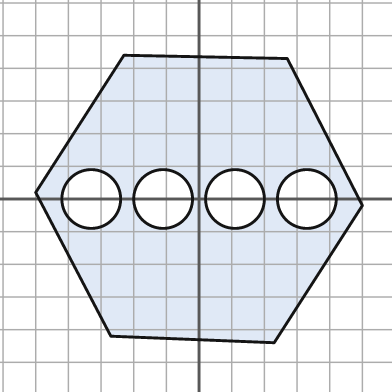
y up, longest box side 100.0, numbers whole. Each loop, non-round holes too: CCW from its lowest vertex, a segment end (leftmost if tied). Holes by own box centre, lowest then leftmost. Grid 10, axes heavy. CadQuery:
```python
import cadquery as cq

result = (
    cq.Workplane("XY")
    .moveTo(23.0, -44.0)
    .lineTo(50.0, -2.0)
    .lineTo(27.0, 43.0)
    .lineTo(-23.0, 44.0)
    .lineTo(-50.0, 2.0)
    .lineTo(-27.0, -42.0)
    .close()
    .moveTo(-33.0, 0.0)
    .circle(9.0)
    .moveTo(-11.0, 0.0)
    .circle(9.0)
    .moveTo(11.0, 0.0)
    .circle(9.0)
    .moveTo(33.0, 0.0)
    .circle(9.0)
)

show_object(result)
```